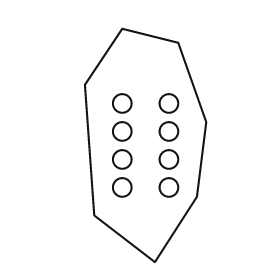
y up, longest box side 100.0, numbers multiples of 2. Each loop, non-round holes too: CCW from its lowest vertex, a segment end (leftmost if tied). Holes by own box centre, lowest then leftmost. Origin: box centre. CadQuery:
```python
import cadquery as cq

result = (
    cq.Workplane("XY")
    .moveTo(4.0, -50.0)
    .lineTo(22.0, -22.0)
    .lineTo(26.0, 10.0)
    .lineTo(14.0, 44.0)
    .lineTo(-10.0, 50.0)
    .lineTo(-26.0, 26.0)
    .lineTo(-22.0, -30.0)
    .close()
    .moveTo(-10.0, -18.0)
    .circle(4.0)
    .moveTo(10.0, -18.0)
    .circle(4.0)
    .moveTo(-10.0, -6.0)
    .circle(4.0)
    .moveTo(10.0, -6.0)
    .circle(4.0)
    .moveTo(-10.0, 6.0)
    .circle(4.0)
    .moveTo(10.0, 6.0)
    .circle(4.0)
    .moveTo(-10.0, 18.0)
    .circle(4.0)
    .moveTo(10.0, 18.0)
    .circle(4.0)
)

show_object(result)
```